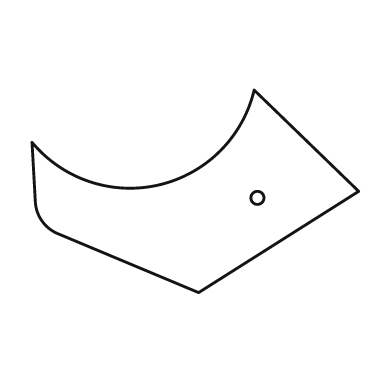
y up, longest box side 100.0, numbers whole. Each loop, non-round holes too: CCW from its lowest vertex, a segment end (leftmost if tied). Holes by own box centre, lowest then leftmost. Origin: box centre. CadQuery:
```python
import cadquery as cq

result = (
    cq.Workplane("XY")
    .moveTo(1.0, -31.0)
    .lineTo(50.0, 0.0)
    .lineTo(18.0, 31.0)
    .threePointArc((-11.0, 2.0), (-50.0, 15.0))
    .lineTo(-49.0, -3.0)
    .threePointArc((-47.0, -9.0), (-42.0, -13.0))
    .close()
    .moveTo(19.0, -2.0)
    .circle(2.0)
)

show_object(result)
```